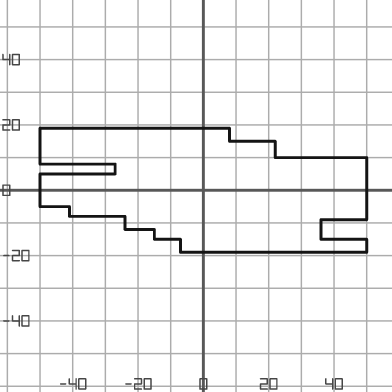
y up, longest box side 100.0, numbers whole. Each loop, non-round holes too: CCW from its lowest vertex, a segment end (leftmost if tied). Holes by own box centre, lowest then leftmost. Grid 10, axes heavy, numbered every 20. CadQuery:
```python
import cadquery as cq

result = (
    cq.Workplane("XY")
    .moveTo(-7.0, -19.0)
    .lineTo(50.0, -19.0)
    .lineTo(50.0, -15.0)
    .lineTo(36.0, -15.0)
    .lineTo(36.0, -9.0)
    .lineTo(50.0, -9.0)
    .lineTo(50.0, 10.0)
    .lineTo(22.0, 10.0)
    .lineTo(22.0, 15.0)
    .lineTo(8.0, 15.0)
    .lineTo(8.0, 19.0)
    .lineTo(-50.0, 19.0)
    .lineTo(-50.0, 8.0)
    .lineTo(-27.0, 8.0)
    .lineTo(-27.0, 5.0)
    .lineTo(-50.0, 5.0)
    .lineTo(-50.0, -5.0)
    .lineTo(-41.0, -5.0)
    .lineTo(-41.0, -8.0)
    .lineTo(-24.0, -8.0)
    .lineTo(-24.0, -12.0)
    .lineTo(-15.0, -12.0)
    .lineTo(-15.0, -15.0)
    .lineTo(-7.0, -15.0)
    .close()
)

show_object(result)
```